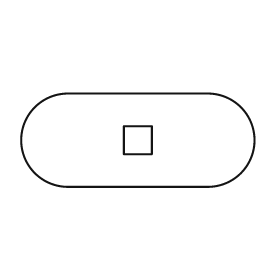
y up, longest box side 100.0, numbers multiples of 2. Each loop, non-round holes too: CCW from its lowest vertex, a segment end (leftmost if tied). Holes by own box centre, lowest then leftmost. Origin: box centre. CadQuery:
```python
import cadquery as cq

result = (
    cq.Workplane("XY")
    .moveTo(-30.0, -20.0)
    .lineTo(30.0, -20.0)
    .threePointArc((50.0, 0.0), (30.0, 20.0))
    .lineTo(-30.0, 20.0)
    .threePointArc((-50.0, 0.0), (-30.0, -20.0))
    .close()
    .moveTo(-6.0, -6.0)
    .lineTo(6.0, -6.0)
    .lineTo(6.0, 6.0)
    .lineTo(-6.0, 6.0)
    .close()
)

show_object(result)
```